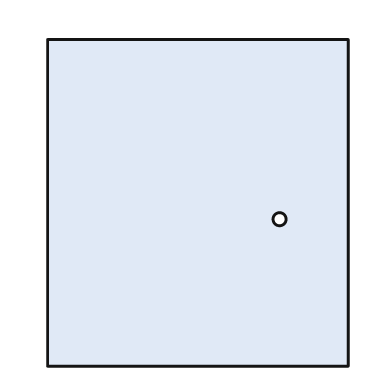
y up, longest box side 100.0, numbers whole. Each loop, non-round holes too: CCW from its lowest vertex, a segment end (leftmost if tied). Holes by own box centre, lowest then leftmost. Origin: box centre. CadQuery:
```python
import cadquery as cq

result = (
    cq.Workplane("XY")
    .moveTo(-46.0, -50.0)
    .lineTo(46.0, -50.0)
    .lineTo(46.0, 50.0)
    .lineTo(-46.0, 50.0)
    .close()
    .moveTo(25.0, -5.0)
    .circle(2.0)
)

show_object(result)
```